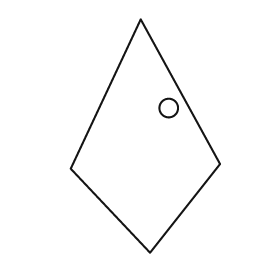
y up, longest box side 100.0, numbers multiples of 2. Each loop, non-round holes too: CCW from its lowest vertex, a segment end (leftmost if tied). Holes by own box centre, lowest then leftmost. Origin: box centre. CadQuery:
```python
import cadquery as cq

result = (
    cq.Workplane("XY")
    .moveTo(2.0, -50.0)
    .lineTo(32.0, -12.0)
    .lineTo(-2.0, 50.0)
    .lineTo(-32.0, -14.0)
    .close()
    .moveTo(10.0, 12.0)
    .circle(4.0)
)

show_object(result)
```